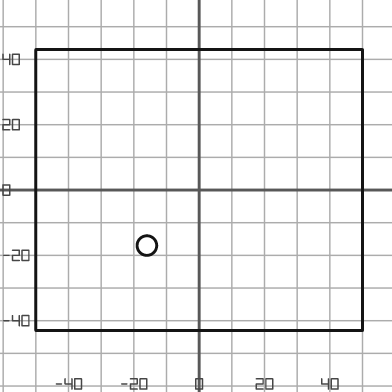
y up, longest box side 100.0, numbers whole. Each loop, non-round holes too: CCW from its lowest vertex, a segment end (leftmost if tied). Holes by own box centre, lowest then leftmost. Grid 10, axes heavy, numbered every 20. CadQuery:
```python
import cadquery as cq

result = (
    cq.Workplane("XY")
    .moveTo(-50.0, -43.0)
    .lineTo(50.0, -43.0)
    .lineTo(50.0, 43.0)
    .lineTo(-50.0, 43.0)
    .close()
    .moveTo(-16.0, -17.0)
    .circle(3.0)
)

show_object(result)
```